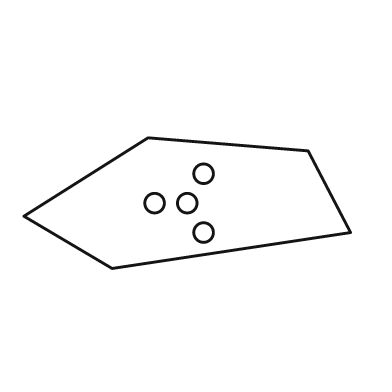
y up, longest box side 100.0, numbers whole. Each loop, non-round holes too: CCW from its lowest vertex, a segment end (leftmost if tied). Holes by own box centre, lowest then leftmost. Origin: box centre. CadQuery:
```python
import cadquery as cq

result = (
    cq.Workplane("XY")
    .moveTo(-23.0, -20.0)
    .lineTo(50.0, -9.0)
    .lineTo(37.0, 16.0)
    .lineTo(-12.0, 20.0)
    .lineTo(-50.0, -4.0)
    .close()
    .moveTo(5.0, -9.0)
    .circle(3.0)
    .moveTo(-10.0, 0.0)
    .circle(3.0)
    .moveTo(0.0, 0.0)
    .circle(3.0)
    .moveTo(5.0, 9.0)
    .circle(3.0)
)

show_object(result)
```